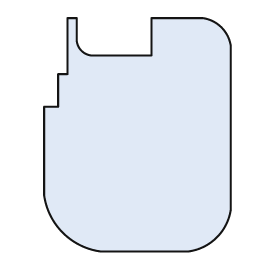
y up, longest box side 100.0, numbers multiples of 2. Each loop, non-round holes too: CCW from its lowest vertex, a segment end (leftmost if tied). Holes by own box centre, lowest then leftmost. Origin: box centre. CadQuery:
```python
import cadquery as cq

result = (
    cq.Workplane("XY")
    .moveTo(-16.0, -50.0)
    .lineTo(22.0, -50.0)
    .threePointArc((34.0, -44.0), (40.0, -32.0))
    .lineTo(40.0, 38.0)
    .threePointArc((36.0, 46.0), (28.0, 50.0))
    .lineTo(6.0, 50.0)
    .lineTo(6.0, 34.0)
    .lineTo(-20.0, 34.0)
    .threePointArc((-24.0, 36.0), (-26.0, 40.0))
    .lineTo(-26.0, 50.0)
    .lineTo(-30.0, 50.0)
    .lineTo(-30.0, 26.0)
    .lineTo(-34.0, 26.0)
    .lineTo(-34.0, 12.0)
    .lineTo(-40.0, 12.0)
    .lineTo(-40.0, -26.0)
    .threePointArc((-32.0, -42.0), (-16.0, -50.0))
    .close()
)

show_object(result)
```